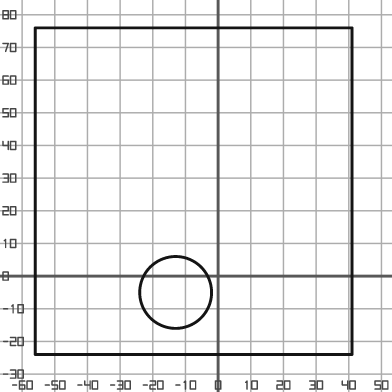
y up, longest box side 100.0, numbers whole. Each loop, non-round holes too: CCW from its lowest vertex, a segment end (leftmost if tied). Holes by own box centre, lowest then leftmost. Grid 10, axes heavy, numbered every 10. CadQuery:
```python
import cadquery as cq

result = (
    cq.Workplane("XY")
    .moveTo(-56.0, -24.0)
    .lineTo(41.0, -24.0)
    .lineTo(41.0, 76.0)
    .lineTo(-56.0, 76.0)
    .close()
    .moveTo(-13.0, -5.0)
    .circle(11.0)
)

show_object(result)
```